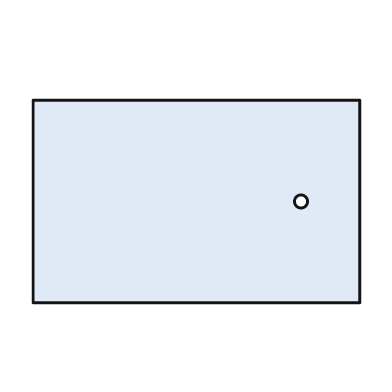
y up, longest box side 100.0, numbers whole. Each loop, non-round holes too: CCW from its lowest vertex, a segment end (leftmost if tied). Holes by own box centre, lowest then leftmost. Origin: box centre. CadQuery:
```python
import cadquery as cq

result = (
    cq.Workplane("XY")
    .moveTo(-50.0, -31.0)
    .lineTo(50.0, -31.0)
    .lineTo(50.0, 31.0)
    .lineTo(-50.0, 31.0)
    .close()
    .moveTo(32.0, 0.0)
    .circle(2.0)
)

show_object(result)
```